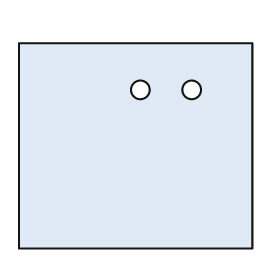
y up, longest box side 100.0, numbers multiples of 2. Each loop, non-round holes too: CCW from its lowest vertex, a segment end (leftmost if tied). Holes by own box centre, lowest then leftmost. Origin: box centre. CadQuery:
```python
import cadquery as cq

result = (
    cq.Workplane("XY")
    .moveTo(-50.0, -44.0)
    .lineTo(50.0, -44.0)
    .lineTo(50.0, 44.0)
    .lineTo(-50.0, 44.0)
    .close()
    .moveTo(2.0, 24.0)
    .circle(4.0)
    .moveTo(24.0, 24.0)
    .circle(4.0)
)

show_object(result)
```